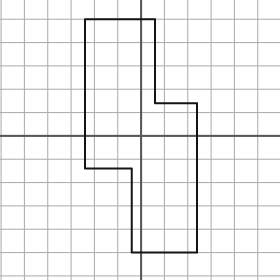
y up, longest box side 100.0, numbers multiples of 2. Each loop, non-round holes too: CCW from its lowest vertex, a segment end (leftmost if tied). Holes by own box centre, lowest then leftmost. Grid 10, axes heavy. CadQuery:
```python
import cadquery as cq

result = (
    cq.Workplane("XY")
    .moveTo(-4.0, -50.0)
    .lineTo(24.0, -50.0)
    .lineTo(24.0, 14.0)
    .lineTo(6.0, 14.0)
    .lineTo(6.0, 50.0)
    .lineTo(-24.0, 50.0)
    .lineTo(-24.0, -14.0)
    .lineTo(-4.0, -14.0)
    .close()
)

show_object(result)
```